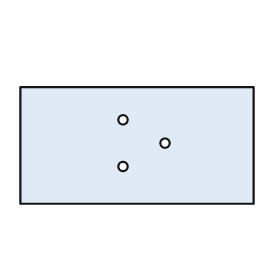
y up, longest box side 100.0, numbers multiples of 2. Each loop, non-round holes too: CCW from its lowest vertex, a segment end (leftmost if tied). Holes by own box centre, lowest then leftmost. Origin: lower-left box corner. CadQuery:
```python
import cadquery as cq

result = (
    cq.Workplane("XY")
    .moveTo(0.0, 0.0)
    .lineTo(100.0, 0.0)
    .lineTo(100.0, 50.0)
    .lineTo(0.0, 50.0)
    .close()
    .moveTo(44.0, 16.0)
    .circle(2.0)
    .moveTo(62.0, 26.0)
    .circle(2.0)
    .moveTo(44.0, 36.0)
    .circle(2.0)
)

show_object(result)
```